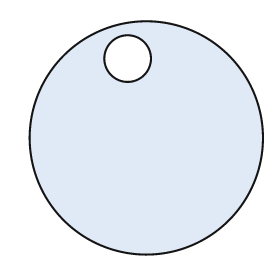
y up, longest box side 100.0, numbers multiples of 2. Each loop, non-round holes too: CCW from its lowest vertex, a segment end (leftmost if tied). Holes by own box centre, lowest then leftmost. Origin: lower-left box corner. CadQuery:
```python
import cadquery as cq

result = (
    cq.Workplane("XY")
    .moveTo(50.0, 50.0)
    .circle(50.0)
    .moveTo(42.0, 84.0)
    .circle(10.0)
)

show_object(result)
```